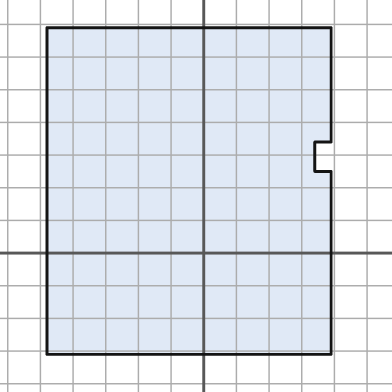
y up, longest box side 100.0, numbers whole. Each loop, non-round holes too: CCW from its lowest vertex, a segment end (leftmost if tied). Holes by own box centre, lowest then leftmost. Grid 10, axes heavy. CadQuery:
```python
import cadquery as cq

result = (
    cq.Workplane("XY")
    .moveTo(-48.0, -31.0)
    .lineTo(39.0, -31.0)
    .lineTo(39.0, 25.0)
    .lineTo(34.0, 25.0)
    .lineTo(34.0, 34.0)
    .lineTo(39.0, 34.0)
    .lineTo(39.0, 69.0)
    .lineTo(-48.0, 69.0)
    .close()
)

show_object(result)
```